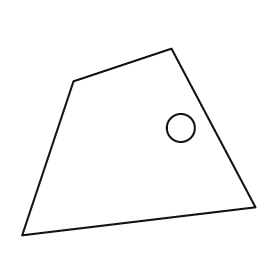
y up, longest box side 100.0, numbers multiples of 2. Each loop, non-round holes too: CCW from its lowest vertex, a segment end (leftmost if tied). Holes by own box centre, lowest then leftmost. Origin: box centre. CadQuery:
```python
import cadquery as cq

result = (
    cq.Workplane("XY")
    .moveTo(-50.0, -40.0)
    .lineTo(50.0, -28.0)
    .lineTo(14.0, 40.0)
    .lineTo(-28.0, 26.0)
    .close()
    .moveTo(18.0, 6.0)
    .circle(6.0)
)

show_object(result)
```